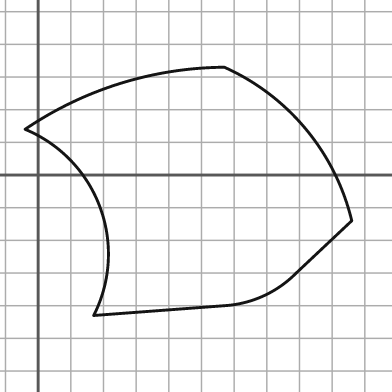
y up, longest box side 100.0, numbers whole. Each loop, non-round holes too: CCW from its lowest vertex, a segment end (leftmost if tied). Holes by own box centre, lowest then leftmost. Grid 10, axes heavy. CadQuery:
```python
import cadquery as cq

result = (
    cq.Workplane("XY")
    .moveTo(17.0, -43.0)
    .lineTo(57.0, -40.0)
    .threePointArc((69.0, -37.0), (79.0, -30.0))
    .lineTo(96.0, -14.0)
    .threePointArc((82.0, 14.0), (57.0, 33.0))
    .threePointArc((25.0, 28.0), (-4.0, 14.0))
    .threePointArc((19.0, -10.0), (17.0, -43.0))
    .close()
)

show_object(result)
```